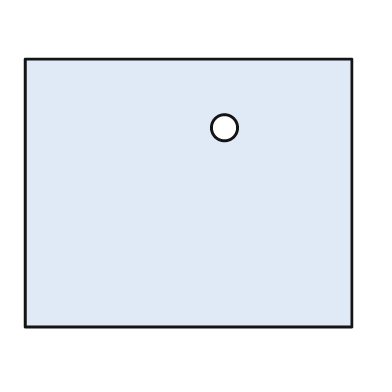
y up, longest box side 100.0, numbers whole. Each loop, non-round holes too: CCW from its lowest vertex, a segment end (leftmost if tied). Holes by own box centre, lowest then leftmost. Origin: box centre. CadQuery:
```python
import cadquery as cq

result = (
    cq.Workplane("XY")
    .moveTo(-50.0, -41.0)
    .lineTo(50.0, -41.0)
    .lineTo(50.0, 41.0)
    .lineTo(-50.0, 41.0)
    .close()
    .moveTo(11.0, 20.0)
    .circle(4.0)
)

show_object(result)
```